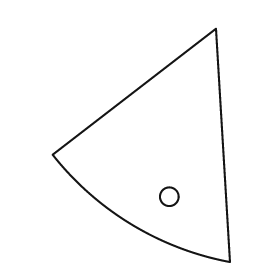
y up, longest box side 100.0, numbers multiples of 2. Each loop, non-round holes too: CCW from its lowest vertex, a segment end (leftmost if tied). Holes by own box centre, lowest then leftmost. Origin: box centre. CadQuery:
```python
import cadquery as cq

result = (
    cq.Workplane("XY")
    .moveTo(38.0, -50.0)
    .lineTo(32.0, 50.0)
    .lineTo(-38.0, -4.0)
    .threePointArc((-4.0, -34.0), (38.0, -50.0))
    .close()
    .moveTo(12.0, -22.0)
    .circle(4.0)
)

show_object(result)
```